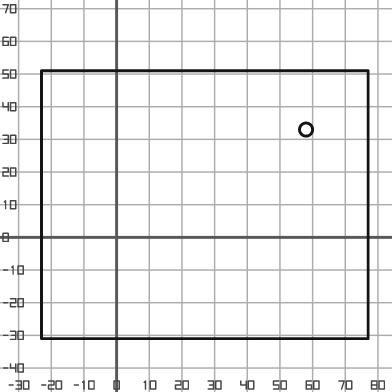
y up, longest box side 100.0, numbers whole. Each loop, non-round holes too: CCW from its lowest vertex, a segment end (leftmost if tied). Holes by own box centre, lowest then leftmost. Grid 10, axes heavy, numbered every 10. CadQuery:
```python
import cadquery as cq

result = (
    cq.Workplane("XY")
    .moveTo(-23.0, -31.0)
    .lineTo(77.0, -31.0)
    .lineTo(77.0, 51.0)
    .lineTo(-23.0, 51.0)
    .close()
    .moveTo(58.0, 33.0)
    .circle(2.0)
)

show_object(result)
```